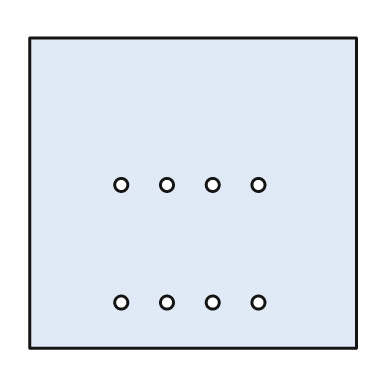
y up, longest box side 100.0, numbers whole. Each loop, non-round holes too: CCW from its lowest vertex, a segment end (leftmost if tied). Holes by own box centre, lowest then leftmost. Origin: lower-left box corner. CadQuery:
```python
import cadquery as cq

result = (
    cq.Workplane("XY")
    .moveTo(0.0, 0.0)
    .lineTo(100.0, 0.0)
    .lineTo(100.0, 95.0)
    .lineTo(0.0, 95.0)
    .close()
    .moveTo(28.0, 14.0)
    .circle(2.0)
    .moveTo(42.0, 14.0)
    .circle(2.0)
    .moveTo(56.0, 14.0)
    .circle(2.0)
    .moveTo(70.0, 14.0)
    .circle(2.0)
    .moveTo(28.0, 50.0)
    .circle(2.0)
    .moveTo(42.0, 50.0)
    .circle(2.0)
    .moveTo(56.0, 50.0)
    .circle(2.0)
    .moveTo(70.0, 50.0)
    .circle(2.0)
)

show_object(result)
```